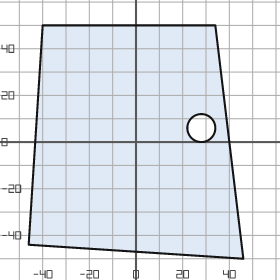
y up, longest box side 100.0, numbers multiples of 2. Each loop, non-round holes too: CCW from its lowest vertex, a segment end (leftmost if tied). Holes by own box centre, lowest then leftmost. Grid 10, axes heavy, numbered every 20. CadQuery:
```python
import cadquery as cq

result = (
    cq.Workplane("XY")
    .moveTo(46.0, -50.0)
    .lineTo(34.0, 50.0)
    .lineTo(-40.0, 50.0)
    .lineTo(-46.0, -44.0)
    .close()
    .moveTo(28.0, 6.0)
    .circle(6.0)
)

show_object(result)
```